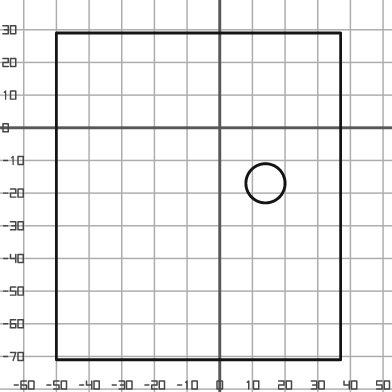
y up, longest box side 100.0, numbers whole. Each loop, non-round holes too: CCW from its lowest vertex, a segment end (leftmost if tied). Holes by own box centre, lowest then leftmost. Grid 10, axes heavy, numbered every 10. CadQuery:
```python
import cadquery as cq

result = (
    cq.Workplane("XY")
    .moveTo(-50.0, -71.0)
    .lineTo(37.0, -71.0)
    .lineTo(37.0, 29.0)
    .lineTo(-50.0, 29.0)
    .close()
    .moveTo(14.0, -17.0)
    .circle(6.0)
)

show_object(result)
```